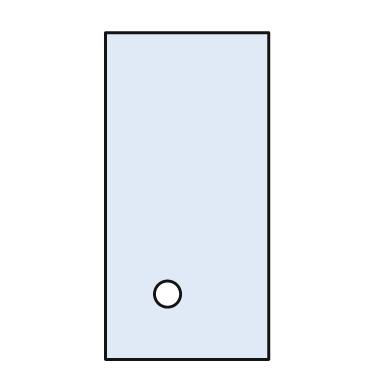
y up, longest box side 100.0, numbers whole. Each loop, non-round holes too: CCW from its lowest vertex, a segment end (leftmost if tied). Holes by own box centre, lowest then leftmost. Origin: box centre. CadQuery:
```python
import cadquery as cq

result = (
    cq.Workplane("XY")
    .moveTo(-25.0, -50.0)
    .lineTo(25.0, -50.0)
    .lineTo(25.0, 50.0)
    .lineTo(-25.0, 50.0)
    .close()
    .moveTo(-6.0, -30.0)
    .circle(4.0)
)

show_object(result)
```